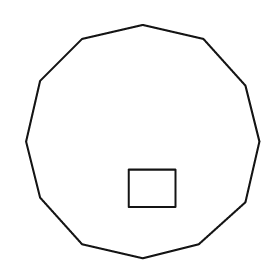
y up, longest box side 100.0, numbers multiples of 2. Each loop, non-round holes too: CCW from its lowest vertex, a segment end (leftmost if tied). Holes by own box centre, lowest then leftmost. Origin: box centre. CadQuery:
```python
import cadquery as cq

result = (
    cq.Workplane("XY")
    .moveTo(0.0, -50.0)
    .lineTo(24.0, -44.0)
    .lineTo(44.0, -26.0)
    .lineTo(50.0, 0.0)
    .lineTo(44.0, 24.0)
    .lineTo(26.0, 44.0)
    .lineTo(0.0, 50.0)
    .lineTo(-26.0, 44.0)
    .lineTo(-44.0, 26.0)
    .lineTo(-50.0, 0.0)
    .lineTo(-44.0, -24.0)
    .lineTo(-26.0, -44.0)
    .close()
    .moveTo(-6.0, -28.0)
    .lineTo(14.0, -28.0)
    .lineTo(14.0, -12.0)
    .lineTo(-6.0, -12.0)
    .close()
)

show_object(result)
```